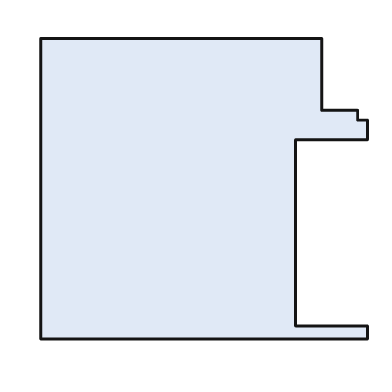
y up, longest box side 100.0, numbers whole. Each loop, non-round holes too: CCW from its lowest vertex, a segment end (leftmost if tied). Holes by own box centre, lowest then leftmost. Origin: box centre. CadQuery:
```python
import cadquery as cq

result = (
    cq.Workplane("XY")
    .moveTo(-50.0, -46.0)
    .lineTo(50.0, -46.0)
    .lineTo(50.0, -42.0)
    .lineTo(28.0, -42.0)
    .lineTo(28.0, 15.0)
    .lineTo(50.0, 15.0)
    .lineTo(50.0, 21.0)
    .lineTo(47.0, 21.0)
    .lineTo(47.0, 24.0)
    .lineTo(36.0, 24.0)
    .lineTo(36.0, 46.0)
    .lineTo(-50.0, 46.0)
    .close()
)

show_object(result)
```